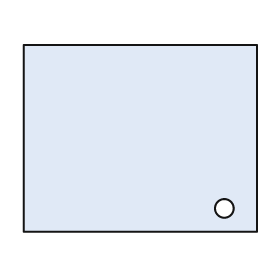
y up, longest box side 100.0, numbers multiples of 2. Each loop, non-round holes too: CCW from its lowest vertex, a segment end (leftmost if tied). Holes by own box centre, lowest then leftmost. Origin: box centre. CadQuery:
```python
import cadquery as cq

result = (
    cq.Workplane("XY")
    .moveTo(-50.0, -40.0)
    .lineTo(50.0, -40.0)
    .lineTo(50.0, 40.0)
    .lineTo(-50.0, 40.0)
    .close()
    .moveTo(36.0, -30.0)
    .circle(4.0)
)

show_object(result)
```